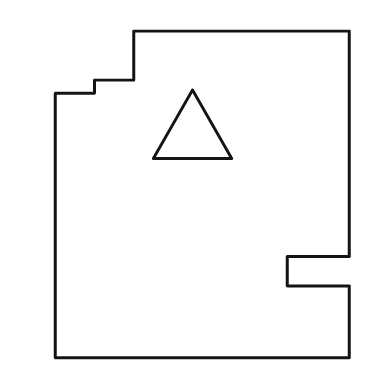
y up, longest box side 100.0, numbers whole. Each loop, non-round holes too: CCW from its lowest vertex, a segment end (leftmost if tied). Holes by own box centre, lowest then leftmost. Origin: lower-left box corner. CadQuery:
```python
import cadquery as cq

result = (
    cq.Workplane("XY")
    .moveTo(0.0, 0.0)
    .lineTo(90.0, 0.0)
    .lineTo(90.0, 22.0)
    .lineTo(71.0, 22.0)
    .lineTo(71.0, 31.0)
    .lineTo(90.0, 31.0)
    .lineTo(90.0, 100.0)
    .lineTo(24.0, 100.0)
    .lineTo(24.0, 85.0)
    .lineTo(12.0, 85.0)
    .lineTo(12.0, 81.0)
    .lineTo(0.0, 81.0)
    .close()
    .moveTo(30.0, 61.0)
    .lineTo(54.0, 61.0)
    .lineTo(42.0, 82.0)
    .close()
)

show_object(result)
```